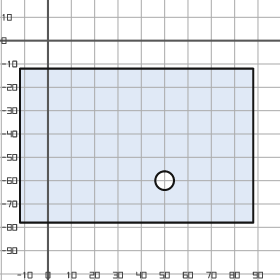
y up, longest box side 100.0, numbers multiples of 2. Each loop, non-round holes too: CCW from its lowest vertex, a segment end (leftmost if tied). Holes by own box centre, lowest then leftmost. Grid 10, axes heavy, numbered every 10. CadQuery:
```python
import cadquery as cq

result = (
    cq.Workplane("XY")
    .moveTo(-12.0, -78.0)
    .lineTo(88.0, -78.0)
    .lineTo(88.0, -12.0)
    .lineTo(-12.0, -12.0)
    .close()
    .moveTo(50.0, -60.0)
    .circle(4.0)
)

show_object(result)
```